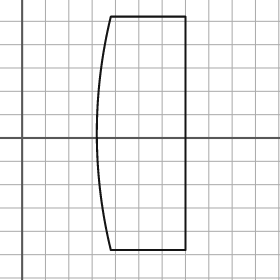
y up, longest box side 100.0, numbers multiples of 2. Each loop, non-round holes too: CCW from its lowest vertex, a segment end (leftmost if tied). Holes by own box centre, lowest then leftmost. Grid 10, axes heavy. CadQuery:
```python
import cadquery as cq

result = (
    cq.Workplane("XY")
    .moveTo(38.0, -48.0)
    .lineTo(70.0, -48.0)
    .lineTo(70.0, 52.0)
    .lineTo(38.0, 52.0)
    .threePointArc((32.0, 2.0), (38.0, -48.0))
    .close()
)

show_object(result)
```